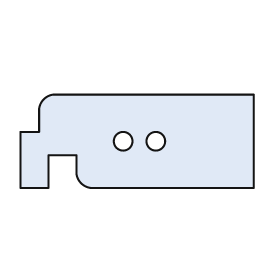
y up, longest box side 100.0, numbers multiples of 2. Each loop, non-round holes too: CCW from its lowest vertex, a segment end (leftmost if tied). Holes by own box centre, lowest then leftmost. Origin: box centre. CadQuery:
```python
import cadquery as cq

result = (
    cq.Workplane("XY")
    .moveTo(-50.0, -20.0)
    .lineTo(-38.0, -20.0)
    .lineTo(-38.0, -6.0)
    .lineTo(-26.0, -6.0)
    .lineTo(-26.0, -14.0)
    .threePointArc((-24.0, -18.0), (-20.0, -20.0))
    .lineTo(50.0, -20.0)
    .lineTo(50.0, 20.0)
    .lineTo(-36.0, 20.0)
    .threePointArc((-40.0, 18.0), (-42.0, 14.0))
    .lineTo(-42.0, 4.0)
    .lineTo(-50.0, 4.0)
    .close()
    .moveTo(-6.0, 0.0)
    .circle(4.0)
    .moveTo(8.0, 0.0)
    .circle(4.0)
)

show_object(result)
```